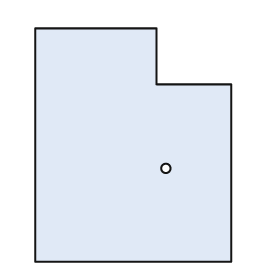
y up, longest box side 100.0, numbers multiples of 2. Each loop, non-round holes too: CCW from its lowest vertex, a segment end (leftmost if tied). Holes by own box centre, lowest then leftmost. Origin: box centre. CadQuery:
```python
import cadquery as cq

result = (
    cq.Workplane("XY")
    .moveTo(-42.0, -50.0)
    .lineTo(42.0, -50.0)
    .lineTo(42.0, 26.0)
    .lineTo(10.0, 26.0)
    .lineTo(10.0, 50.0)
    .lineTo(-42.0, 50.0)
    .close()
    .moveTo(14.0, -10.0)
    .circle(2.0)
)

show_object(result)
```